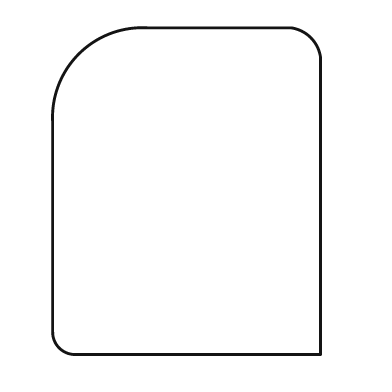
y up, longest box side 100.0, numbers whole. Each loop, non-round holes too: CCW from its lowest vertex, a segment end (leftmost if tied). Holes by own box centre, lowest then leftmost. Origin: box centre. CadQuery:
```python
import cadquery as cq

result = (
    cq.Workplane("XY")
    .moveTo(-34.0, -50.0)
    .lineTo(41.0, -50.0)
    .lineTo(41.0, 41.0)
    .threePointArc((38.0, 47.0), (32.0, 50.0))
    .lineTo(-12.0, 50.0)
    .threePointArc((-33.0, 42.0), (-41.0, 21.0))
    .lineTo(-41.0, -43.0)
    .threePointArc((-39.0, -48.0), (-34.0, -50.0))
    .close()
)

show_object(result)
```